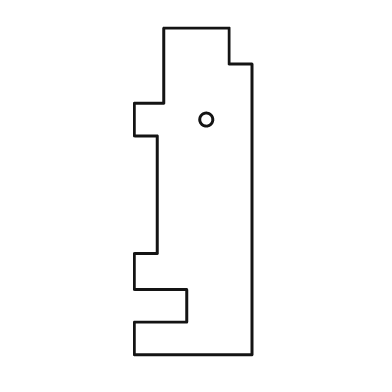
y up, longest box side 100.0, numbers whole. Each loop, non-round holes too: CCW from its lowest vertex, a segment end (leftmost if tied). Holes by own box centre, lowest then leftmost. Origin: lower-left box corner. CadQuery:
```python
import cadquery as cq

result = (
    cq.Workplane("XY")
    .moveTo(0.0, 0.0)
    .lineTo(36.0, 0.0)
    .lineTo(36.0, 89.0)
    .lineTo(29.0, 89.0)
    .lineTo(29.0, 100.0)
    .lineTo(9.0, 100.0)
    .lineTo(9.0, 77.0)
    .lineTo(0.0, 77.0)
    .lineTo(0.0, 67.0)
    .lineTo(7.0, 67.0)
    .lineTo(7.0, 31.0)
    .lineTo(0.0, 31.0)
    .lineTo(0.0, 20.0)
    .lineTo(16.0, 20.0)
    .lineTo(16.0, 10.0)
    .lineTo(0.0, 10.0)
    .close()
    .moveTo(22.0, 72.0)
    .circle(2.0)
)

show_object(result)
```